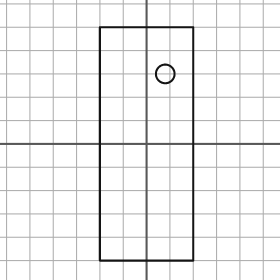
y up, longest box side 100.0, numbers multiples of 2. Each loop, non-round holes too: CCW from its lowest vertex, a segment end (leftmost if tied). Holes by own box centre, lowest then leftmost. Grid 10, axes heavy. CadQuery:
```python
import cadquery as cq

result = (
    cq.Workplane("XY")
    .moveTo(-20.0, -50.0)
    .lineTo(20.0, -50.0)
    .lineTo(20.0, 50.0)
    .lineTo(-20.0, 50.0)
    .close()
    .moveTo(8.0, 30.0)
    .circle(4.0)
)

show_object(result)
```